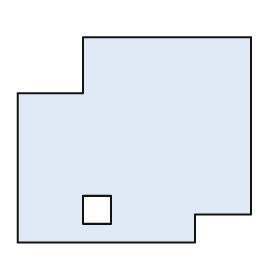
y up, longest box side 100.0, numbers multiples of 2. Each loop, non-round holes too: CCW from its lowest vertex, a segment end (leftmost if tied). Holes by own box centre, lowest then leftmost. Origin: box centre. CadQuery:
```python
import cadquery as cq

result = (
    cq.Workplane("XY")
    .moveTo(-50.0, -44.0)
    .lineTo(26.0, -44.0)
    .lineTo(26.0, -32.0)
    .lineTo(50.0, -32.0)
    .lineTo(50.0, 44.0)
    .lineTo(-22.0, 44.0)
    .lineTo(-22.0, 20.0)
    .lineTo(-50.0, 20.0)
    .close()
    .moveTo(-22.0, -36.0)
    .lineTo(-10.0, -36.0)
    .lineTo(-10.0, -24.0)
    .lineTo(-22.0, -24.0)
    .close()
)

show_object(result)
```